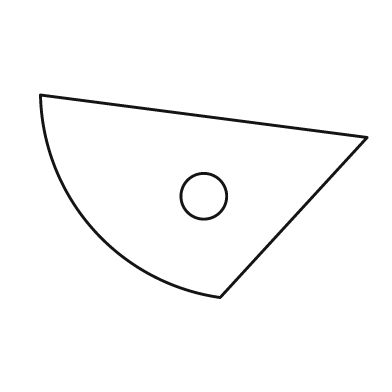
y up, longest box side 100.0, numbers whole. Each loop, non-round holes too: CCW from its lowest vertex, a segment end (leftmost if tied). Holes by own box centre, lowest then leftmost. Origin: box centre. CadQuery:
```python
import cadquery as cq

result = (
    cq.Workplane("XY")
    .moveTo(5.0, -31.0)
    .lineTo(50.0, 18.0)
    .lineTo(-50.0, 31.0)
    .threePointArc((-34.0, -10.0), (5.0, -31.0))
    .close()
    .moveTo(0.0, 0.0)
    .circle(7.0)
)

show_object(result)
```